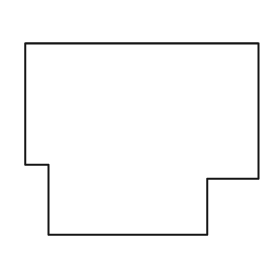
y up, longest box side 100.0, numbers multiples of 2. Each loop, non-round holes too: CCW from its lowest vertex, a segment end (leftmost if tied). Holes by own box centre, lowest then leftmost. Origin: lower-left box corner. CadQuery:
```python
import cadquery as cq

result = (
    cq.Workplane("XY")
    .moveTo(10.0, 0.0)
    .lineTo(78.0, 0.0)
    .lineTo(78.0, 24.0)
    .lineTo(100.0, 24.0)
    .lineTo(100.0, 82.0)
    .lineTo(0.0, 82.0)
    .lineTo(0.0, 30.0)
    .lineTo(10.0, 30.0)
    .close()
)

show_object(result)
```